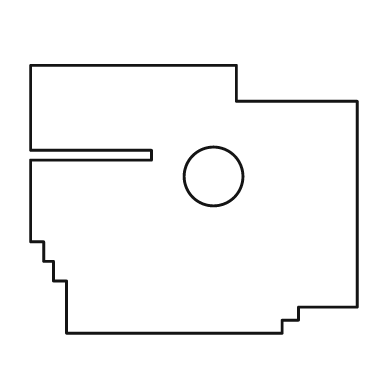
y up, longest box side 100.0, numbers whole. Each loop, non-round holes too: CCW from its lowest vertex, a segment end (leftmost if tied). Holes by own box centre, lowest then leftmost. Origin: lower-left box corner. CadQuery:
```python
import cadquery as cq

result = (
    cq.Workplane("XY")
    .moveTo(11.0, 0.0)
    .lineTo(77.0, 0.0)
    .lineTo(77.0, 4.0)
    .lineTo(82.0, 4.0)
    .lineTo(82.0, 8.0)
    .lineTo(100.0, 8.0)
    .lineTo(100.0, 71.0)
    .lineTo(63.0, 71.0)
    .lineTo(63.0, 82.0)
    .lineTo(0.0, 82.0)
    .lineTo(0.0, 56.0)
    .lineTo(37.0, 56.0)
    .lineTo(37.0, 53.0)
    .lineTo(0.0, 53.0)
    .lineTo(0.0, 28.0)
    .lineTo(4.0, 28.0)
    .lineTo(4.0, 22.0)
    .lineTo(7.0, 22.0)
    .lineTo(7.0, 16.0)
    .lineTo(11.0, 16.0)
    .close()
    .moveTo(56.0, 48.0)
    .circle(9.0)
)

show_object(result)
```